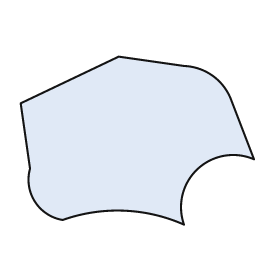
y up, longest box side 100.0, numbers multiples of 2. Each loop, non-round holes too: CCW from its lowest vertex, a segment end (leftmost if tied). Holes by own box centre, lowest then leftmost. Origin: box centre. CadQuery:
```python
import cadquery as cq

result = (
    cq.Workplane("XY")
    .moveTo(20.0, -36.0)
    .threePointArc((26.0, -12.0), (50.0, -8.0))
    .lineTo(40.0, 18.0)
    .threePointArc((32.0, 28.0), (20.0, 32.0))
    .lineTo(-8.0, 36.0)
    .lineTo(-50.0, 16.0)
    .lineTo(-46.0, -12.0)
    .threePointArc((-44.0, -26.0), (-32.0, -34.0))
    .threePointArc((-6.0, -30.0), (20.0, -36.0))
    .close()
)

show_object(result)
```